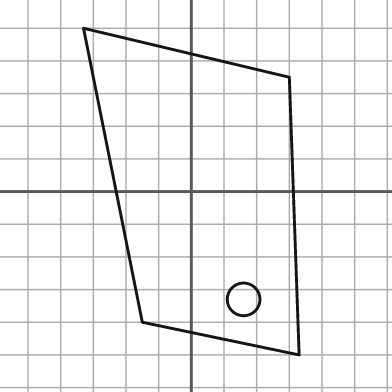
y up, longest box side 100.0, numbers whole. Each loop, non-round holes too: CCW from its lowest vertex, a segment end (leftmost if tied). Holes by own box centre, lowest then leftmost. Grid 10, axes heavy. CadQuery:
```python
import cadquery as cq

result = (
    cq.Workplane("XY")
    .moveTo(33.0, -50.0)
    .lineTo(30.0, 35.0)
    .lineTo(-33.0, 50.0)
    .lineTo(-15.0, -40.0)
    .close()
    .moveTo(16.0, -33.0)
    .circle(5.0)
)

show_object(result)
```